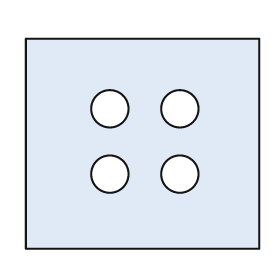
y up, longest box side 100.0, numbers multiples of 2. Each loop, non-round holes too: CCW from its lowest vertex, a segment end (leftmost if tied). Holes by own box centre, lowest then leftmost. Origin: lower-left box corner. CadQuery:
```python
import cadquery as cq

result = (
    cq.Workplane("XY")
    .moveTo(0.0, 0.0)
    .lineTo(100.0, 0.0)
    .lineTo(100.0, 90.0)
    .lineTo(0.0, 90.0)
    .close()
    .moveTo(36.0, 32.0)
    .circle(8.0)
    .moveTo(66.0, 32.0)
    .circle(8.0)
    .moveTo(36.0, 60.0)
    .circle(8.0)
    .moveTo(66.0, 60.0)
    .circle(8.0)
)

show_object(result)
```